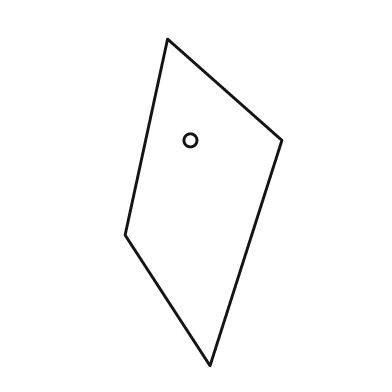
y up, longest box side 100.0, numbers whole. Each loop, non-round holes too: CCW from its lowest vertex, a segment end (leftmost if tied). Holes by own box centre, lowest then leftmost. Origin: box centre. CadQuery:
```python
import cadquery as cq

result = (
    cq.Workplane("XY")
    .moveTo(2.0, -50.0)
    .lineTo(24.0, 19.0)
    .lineTo(-11.0, 50.0)
    .lineTo(-24.0, -10.0)
    .close()
    .moveTo(-4.0, 19.0)
    .circle(2.0)
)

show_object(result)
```